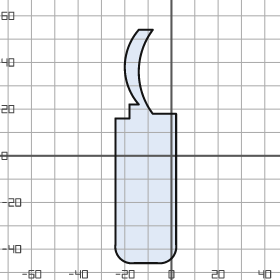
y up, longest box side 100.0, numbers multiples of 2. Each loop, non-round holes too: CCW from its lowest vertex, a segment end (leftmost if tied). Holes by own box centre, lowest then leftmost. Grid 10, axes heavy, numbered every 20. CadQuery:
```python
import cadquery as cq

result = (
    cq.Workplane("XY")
    .moveTo(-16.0, -46.0)
    .lineTo(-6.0, -46.0)
    .threePointArc((0.0, -44.0), (2.0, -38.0))
    .lineTo(2.0, 18.0)
    .lineTo(-8.0, 18.0)
    .threePointArc((-14.0, 36.0), (-8.0, 54.0))
    .lineTo(-14.0, 54.0)
    .threePointArc((-20.0, 38.0), (-14.0, 22.0))
    .lineTo(-18.0, 22.0)
    .lineTo(-18.0, 16.0)
    .lineTo(-24.0, 16.0)
    .lineTo(-24.0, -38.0)
    .threePointArc((-22.0, -44.0), (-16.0, -46.0))
    .close()
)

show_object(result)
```